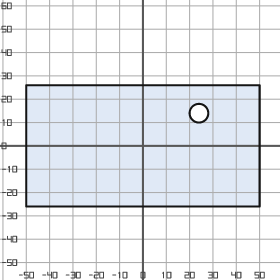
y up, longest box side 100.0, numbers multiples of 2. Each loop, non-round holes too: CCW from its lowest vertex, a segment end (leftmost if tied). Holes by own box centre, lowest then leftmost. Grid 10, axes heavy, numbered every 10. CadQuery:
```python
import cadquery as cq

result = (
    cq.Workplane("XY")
    .moveTo(-50.0, -26.0)
    .lineTo(50.0, -26.0)
    .lineTo(50.0, 26.0)
    .lineTo(-50.0, 26.0)
    .close()
    .moveTo(24.0, 14.0)
    .circle(4.0)
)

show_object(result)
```